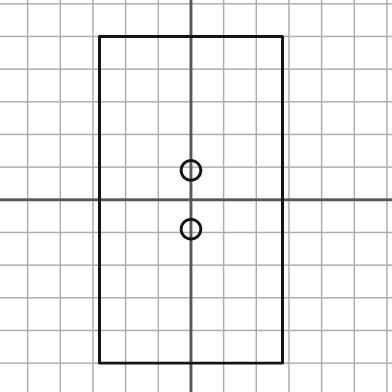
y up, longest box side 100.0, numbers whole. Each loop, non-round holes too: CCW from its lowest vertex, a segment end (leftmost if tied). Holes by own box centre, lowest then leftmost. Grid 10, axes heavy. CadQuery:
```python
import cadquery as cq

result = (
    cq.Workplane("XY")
    .moveTo(-28.0, -50.0)
    .lineTo(28.0, -50.0)
    .lineTo(28.0, 50.0)
    .lineTo(-28.0, 50.0)
    .close()
    .moveTo(0.0, -9.0)
    .circle(3.0)
    .moveTo(0.0, 9.0)
    .circle(3.0)
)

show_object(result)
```